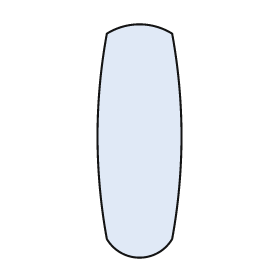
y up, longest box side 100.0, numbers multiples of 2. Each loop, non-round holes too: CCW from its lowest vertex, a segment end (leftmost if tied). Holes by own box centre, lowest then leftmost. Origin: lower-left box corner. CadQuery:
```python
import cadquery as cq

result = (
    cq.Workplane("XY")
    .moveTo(4.0, 8.0)
    .threePointArc((18.0, 0.0), (32.0, 8.0))
    .threePointArc((36.0, 52.0), (32.0, 96.0))
    .threePointArc((18.0, 100.0), (4.0, 96.0))
    .threePointArc((0.0, 52.0), (4.0, 8.0))
    .close()
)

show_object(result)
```